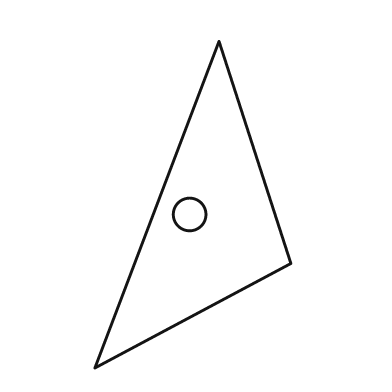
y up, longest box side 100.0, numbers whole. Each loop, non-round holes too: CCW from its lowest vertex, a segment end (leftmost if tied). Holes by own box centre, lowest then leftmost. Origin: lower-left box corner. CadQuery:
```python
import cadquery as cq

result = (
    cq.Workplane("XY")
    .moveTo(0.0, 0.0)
    .lineTo(60.0, 32.0)
    .lineTo(38.0, 100.0)
    .close()
    .moveTo(29.0, 47.0)
    .circle(5.0)
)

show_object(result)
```